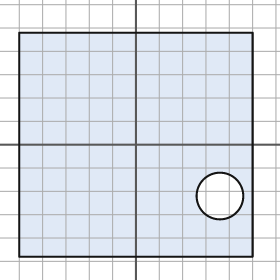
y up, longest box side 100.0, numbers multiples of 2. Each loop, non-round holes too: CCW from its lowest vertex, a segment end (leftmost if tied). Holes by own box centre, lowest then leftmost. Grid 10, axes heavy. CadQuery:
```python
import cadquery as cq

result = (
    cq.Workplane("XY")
    .moveTo(-50.0, -48.0)
    .lineTo(50.0, -48.0)
    .lineTo(50.0, 48.0)
    .lineTo(-50.0, 48.0)
    .close()
    .moveTo(36.0, -22.0)
    .circle(10.0)
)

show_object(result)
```